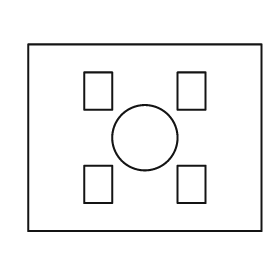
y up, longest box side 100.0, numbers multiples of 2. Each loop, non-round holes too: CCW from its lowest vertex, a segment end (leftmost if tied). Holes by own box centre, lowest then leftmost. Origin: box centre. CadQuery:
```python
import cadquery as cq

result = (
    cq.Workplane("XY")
    .moveTo(-50.0, -40.0)
    .lineTo(50.0, -40.0)
    .lineTo(50.0, 40.0)
    .lineTo(-50.0, 40.0)
    .close()
    .moveTo(-26.0, -28.0)
    .lineTo(-14.0, -28.0)
    .lineTo(-14.0, -12.0)
    .lineTo(-26.0, -12.0)
    .close()
    .moveTo(14.0, -28.0)
    .lineTo(26.0, -28.0)
    .lineTo(26.0, -12.0)
    .lineTo(14.0, -12.0)
    .close()
    .moveTo(0.0, 0.0)
    .circle(14.0)
    .moveTo(-26.0, 12.0)
    .lineTo(-14.0, 12.0)
    .lineTo(-14.0, 28.0)
    .lineTo(-26.0, 28.0)
    .close()
    .moveTo(14.0, 12.0)
    .lineTo(26.0, 12.0)
    .lineTo(26.0, 28.0)
    .lineTo(14.0, 28.0)
    .close()
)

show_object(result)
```